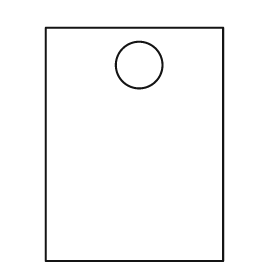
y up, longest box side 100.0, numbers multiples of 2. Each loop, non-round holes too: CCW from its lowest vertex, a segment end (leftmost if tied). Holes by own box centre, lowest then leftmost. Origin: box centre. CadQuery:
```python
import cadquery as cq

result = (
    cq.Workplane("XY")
    .moveTo(-38.0, -50.0)
    .lineTo(38.0, -50.0)
    .lineTo(38.0, 50.0)
    .lineTo(-38.0, 50.0)
    .close()
    .moveTo(2.0, 34.0)
    .circle(10.0)
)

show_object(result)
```